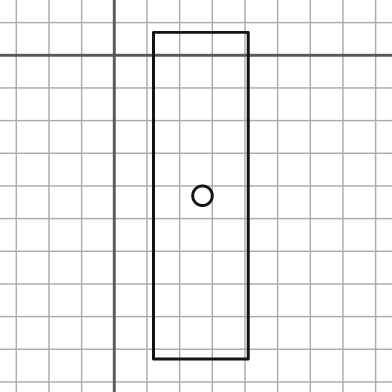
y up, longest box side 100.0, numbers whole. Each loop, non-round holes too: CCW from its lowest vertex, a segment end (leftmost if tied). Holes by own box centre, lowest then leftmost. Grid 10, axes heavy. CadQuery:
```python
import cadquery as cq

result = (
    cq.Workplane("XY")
    .moveTo(12.0, -93.0)
    .lineTo(41.0, -93.0)
    .lineTo(41.0, 7.0)
    .lineTo(12.0, 7.0)
    .close()
    .moveTo(27.0, -43.0)
    .circle(3.0)
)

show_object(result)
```